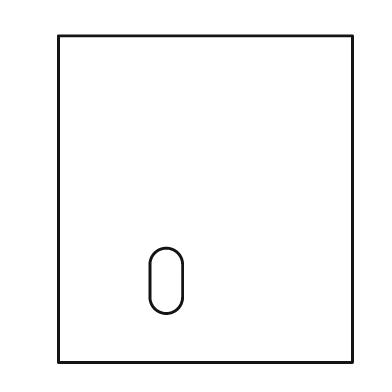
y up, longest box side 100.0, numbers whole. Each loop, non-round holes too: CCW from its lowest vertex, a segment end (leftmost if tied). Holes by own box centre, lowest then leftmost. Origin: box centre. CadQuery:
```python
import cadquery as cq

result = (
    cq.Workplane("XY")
    .moveTo(-45.0, -50.0)
    .lineTo(45.0, -50.0)
    .lineTo(45.0, 50.0)
    .lineTo(-45.0, 50.0)
    .close()
    .moveTo(-17.0, -30.0)
    .threePointArc((-12.0, -35.0), (-7.0, -30.0))
    .lineTo(-7.0, -20.0)
    .threePointArc((-12.0, -15.0), (-17.0, -20.0))
    .close()
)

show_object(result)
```